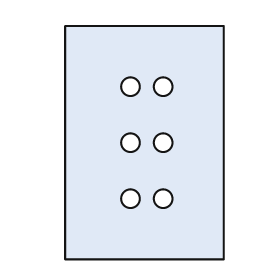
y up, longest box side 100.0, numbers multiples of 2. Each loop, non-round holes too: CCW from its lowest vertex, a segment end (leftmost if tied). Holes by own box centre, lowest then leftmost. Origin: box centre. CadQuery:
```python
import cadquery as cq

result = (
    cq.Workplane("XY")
    .moveTo(-34.0, -50.0)
    .lineTo(34.0, -50.0)
    .lineTo(34.0, 50.0)
    .lineTo(-34.0, 50.0)
    .close()
    .moveTo(-6.0, -24.0)
    .circle(4.0)
    .moveTo(8.0, -24.0)
    .circle(4.0)
    .moveTo(-6.0, 0.0)
    .circle(4.0)
    .moveTo(8.0, 0.0)
    .circle(4.0)
    .moveTo(-6.0, 24.0)
    .circle(4.0)
    .moveTo(8.0, 24.0)
    .circle(4.0)
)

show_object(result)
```